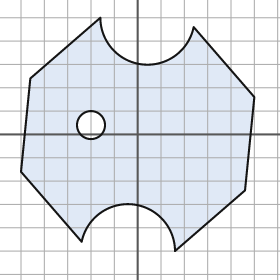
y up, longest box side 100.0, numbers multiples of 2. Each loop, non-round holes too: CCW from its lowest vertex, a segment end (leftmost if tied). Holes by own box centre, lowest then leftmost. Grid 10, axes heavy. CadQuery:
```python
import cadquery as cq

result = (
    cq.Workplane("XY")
    .moveTo(16.0, -50.0)
    .lineTo(46.0, -24.0)
    .lineTo(50.0, 16.0)
    .lineTo(24.0, 46.0)
    .threePointArc((2.0, 30.0), (-16.0, 50.0))
    .lineTo(-46.0, 24.0)
    .lineTo(-50.0, -16.0)
    .lineTo(-24.0, -46.0)
    .threePointArc((-2.0, -30.0), (16.0, -50.0))
    .close()
    .moveTo(-20.0, 4.0)
    .circle(6.0)
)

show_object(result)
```